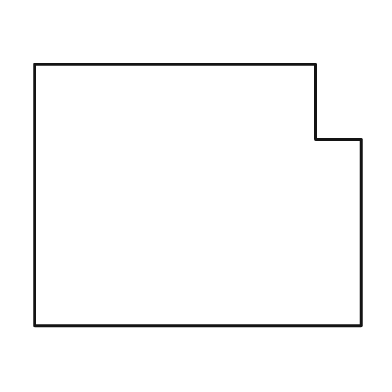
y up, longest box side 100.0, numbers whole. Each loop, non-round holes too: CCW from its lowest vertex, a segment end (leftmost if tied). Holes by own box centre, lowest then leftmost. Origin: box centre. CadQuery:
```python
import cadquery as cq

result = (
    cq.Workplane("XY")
    .moveTo(-50.0, -40.0)
    .lineTo(50.0, -40.0)
    .lineTo(50.0, 17.0)
    .lineTo(36.0, 17.0)
    .lineTo(36.0, 40.0)
    .lineTo(-50.0, 40.0)
    .close()
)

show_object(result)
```